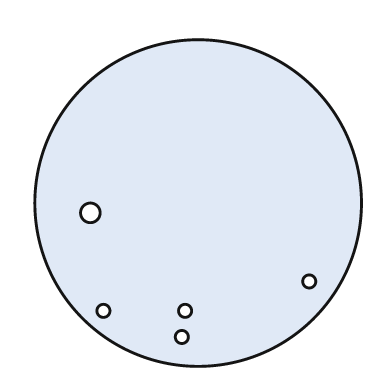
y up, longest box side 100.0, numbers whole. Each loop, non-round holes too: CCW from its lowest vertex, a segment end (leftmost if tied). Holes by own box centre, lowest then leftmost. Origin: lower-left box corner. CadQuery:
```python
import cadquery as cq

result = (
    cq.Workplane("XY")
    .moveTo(50.0, 50.0)
    .circle(50.0)
    .moveTo(45.0, 9.0)
    .circle(2.0)
    .moveTo(21.0, 17.0)
    .circle(2.0)
    .moveTo(46.0, 17.0)
    .circle(2.0)
    .moveTo(84.0, 26.0)
    .circle(2.0)
    .moveTo(17.0, 47.0)
    .circle(3.0)
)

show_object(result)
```